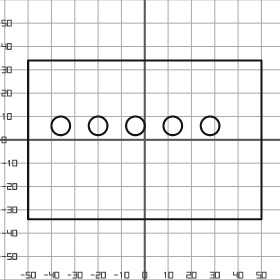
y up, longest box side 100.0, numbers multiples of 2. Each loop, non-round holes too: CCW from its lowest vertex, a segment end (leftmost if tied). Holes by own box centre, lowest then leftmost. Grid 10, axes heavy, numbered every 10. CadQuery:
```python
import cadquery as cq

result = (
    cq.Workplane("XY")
    .moveTo(-50.0, -34.0)
    .lineTo(50.0, -34.0)
    .lineTo(50.0, 34.0)
    .lineTo(-50.0, 34.0)
    .close()
    .moveTo(-36.0, 6.0)
    .circle(4.0)
    .moveTo(-20.0, 6.0)
    .circle(4.0)
    .moveTo(-4.0, 6.0)
    .circle(4.0)
    .moveTo(12.0, 6.0)
    .circle(4.0)
    .moveTo(28.0, 6.0)
    .circle(4.0)
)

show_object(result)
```